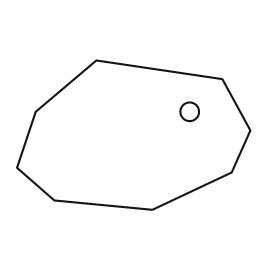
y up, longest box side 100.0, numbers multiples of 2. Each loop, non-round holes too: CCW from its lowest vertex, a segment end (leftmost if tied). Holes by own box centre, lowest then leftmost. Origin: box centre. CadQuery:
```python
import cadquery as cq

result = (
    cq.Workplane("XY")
    .moveTo(8.0, -32.0)
    .lineTo(42.0, -16.0)
    .lineTo(50.0, 2.0)
    .lineTo(38.0, 24.0)
    .lineTo(-16.0, 32.0)
    .lineTo(-42.0, 10.0)
    .lineTo(-50.0, -14.0)
    .lineTo(-34.0, -28.0)
    .close()
    .moveTo(24.0, 10.0)
    .circle(4.0)
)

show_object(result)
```